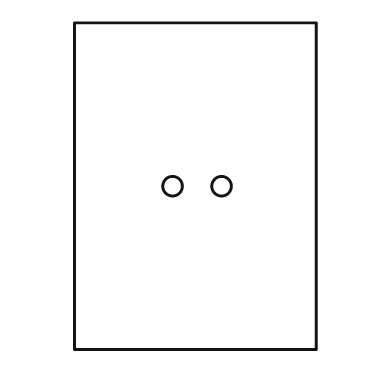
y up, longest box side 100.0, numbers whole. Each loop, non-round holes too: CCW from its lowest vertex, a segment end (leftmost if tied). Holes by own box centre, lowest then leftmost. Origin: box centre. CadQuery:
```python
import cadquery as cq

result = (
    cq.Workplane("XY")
    .moveTo(-37.0, -50.0)
    .lineTo(37.0, -50.0)
    .lineTo(37.0, 50.0)
    .lineTo(-37.0, 50.0)
    .close()
    .moveTo(-7.0, 0.0)
    .circle(3.0)
    .moveTo(8.0, 0.0)
    .circle(3.0)
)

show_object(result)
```